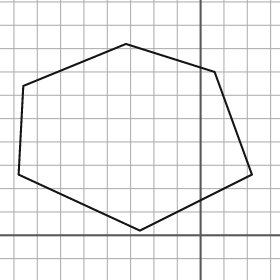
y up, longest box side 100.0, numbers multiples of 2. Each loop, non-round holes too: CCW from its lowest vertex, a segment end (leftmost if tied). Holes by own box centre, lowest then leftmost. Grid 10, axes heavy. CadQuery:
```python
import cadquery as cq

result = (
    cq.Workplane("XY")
    .moveTo(-26.0, 2.0)
    .lineTo(22.0, 26.0)
    .lineTo(6.0, 70.0)
    .lineTo(-32.0, 82.0)
    .lineTo(-76.0, 64.0)
    .lineTo(-78.0, 26.0)
    .close()
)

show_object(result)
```